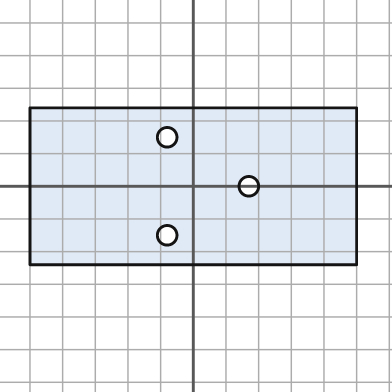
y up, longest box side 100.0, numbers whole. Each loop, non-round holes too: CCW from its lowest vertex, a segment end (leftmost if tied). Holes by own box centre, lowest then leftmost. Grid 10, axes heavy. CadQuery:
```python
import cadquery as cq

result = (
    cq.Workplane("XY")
    .moveTo(-50.0, -24.0)
    .lineTo(50.0, -24.0)
    .lineTo(50.0, 24.0)
    .lineTo(-50.0, 24.0)
    .close()
    .moveTo(-8.0, -15.0)
    .circle(3.0)
    .moveTo(17.0, 0.0)
    .circle(3.0)
    .moveTo(-8.0, 15.0)
    .circle(3.0)
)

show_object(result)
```